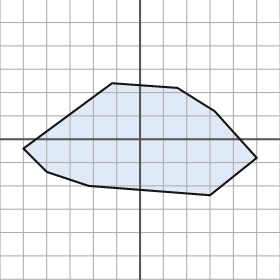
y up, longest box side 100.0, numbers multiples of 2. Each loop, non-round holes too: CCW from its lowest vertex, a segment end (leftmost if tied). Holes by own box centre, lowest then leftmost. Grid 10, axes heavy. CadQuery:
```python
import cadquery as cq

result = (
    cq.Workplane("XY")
    .moveTo(30.0, -24.0)
    .lineTo(50.0, -8.0)
    .lineTo(32.0, 12.0)
    .lineTo(16.0, 22.0)
    .lineTo(-12.0, 24.0)
    .lineTo(-50.0, -4.0)
    .lineTo(-40.0, -14.0)
    .lineTo(-22.0, -20.0)
    .close()
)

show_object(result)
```